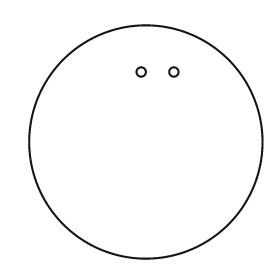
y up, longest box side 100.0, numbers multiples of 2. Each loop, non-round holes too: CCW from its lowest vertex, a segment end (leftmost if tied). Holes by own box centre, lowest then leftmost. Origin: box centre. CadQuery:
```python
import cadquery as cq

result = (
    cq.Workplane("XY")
    .moveTo(0.0, 0.0)
    .circle(50.0)
    .moveTo(-2.0, 30.0)
    .circle(2.0)
    .moveTo(12.0, 30.0)
    .circle(2.0)
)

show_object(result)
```